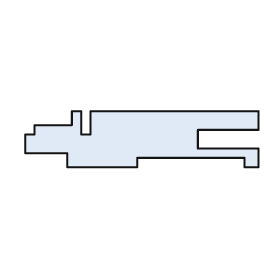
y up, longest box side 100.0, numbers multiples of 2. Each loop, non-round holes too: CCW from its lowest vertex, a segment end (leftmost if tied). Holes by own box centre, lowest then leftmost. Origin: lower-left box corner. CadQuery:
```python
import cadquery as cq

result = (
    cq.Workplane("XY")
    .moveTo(18.0, 0.0)
    .lineTo(48.0, 0.0)
    .lineTo(48.0, 4.0)
    .lineTo(94.0, 4.0)
    .lineTo(94.0, 0.0)
    .lineTo(100.0, 0.0)
    .lineTo(100.0, 8.0)
    .lineTo(74.0, 8.0)
    .lineTo(74.0, 16.0)
    .lineTo(100.0, 16.0)
    .lineTo(100.0, 24.0)
    .lineTo(28.0, 24.0)
    .lineTo(28.0, 14.0)
    .lineTo(24.0, 14.0)
    .lineTo(24.0, 24.0)
    .lineTo(20.0, 24.0)
    .lineTo(20.0, 18.0)
    .lineTo(4.0, 18.0)
    .lineTo(4.0, 14.0)
    .lineTo(0.0, 14.0)
    .lineTo(0.0, 6.0)
    .lineTo(18.0, 6.0)
    .close()
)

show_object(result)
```